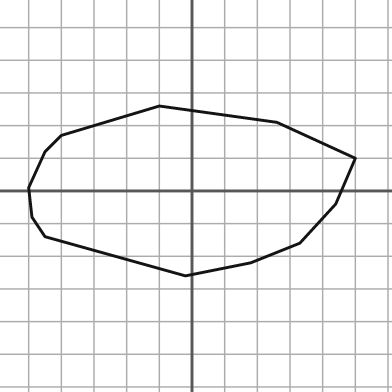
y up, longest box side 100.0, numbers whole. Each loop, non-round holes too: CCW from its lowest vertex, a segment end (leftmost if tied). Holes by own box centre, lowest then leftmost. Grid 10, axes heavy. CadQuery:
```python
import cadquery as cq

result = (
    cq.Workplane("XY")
    .moveTo(-2.0, -26.0)
    .lineTo(18.0, -22.0)
    .lineTo(33.0, -16.0)
    .lineTo(44.0, -4.0)
    .lineTo(50.0, 10.0)
    .lineTo(26.0, 21.0)
    .lineTo(-10.0, 26.0)
    .lineTo(-40.0, 17.0)
    .lineTo(-45.0, 12.0)
    .lineTo(-50.0, 1.0)
    .lineTo(-49.0, -8.0)
    .lineTo(-45.0, -14.0)
    .close()
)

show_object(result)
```